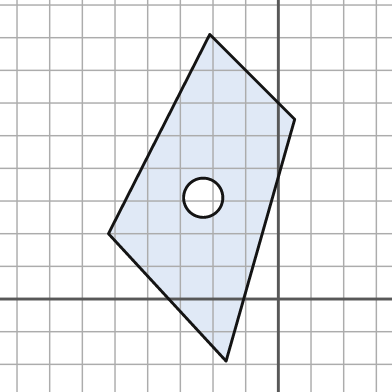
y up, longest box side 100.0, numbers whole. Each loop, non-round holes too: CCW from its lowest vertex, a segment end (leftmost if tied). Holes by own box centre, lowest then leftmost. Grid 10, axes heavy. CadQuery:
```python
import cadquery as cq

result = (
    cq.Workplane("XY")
    .moveTo(-16.0, -19.0)
    .lineTo(5.0, 55.0)
    .lineTo(-21.0, 81.0)
    .lineTo(-52.0, 20.0)
    .close()
    .moveTo(-23.0, 31.0)
    .circle(6.0)
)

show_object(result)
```